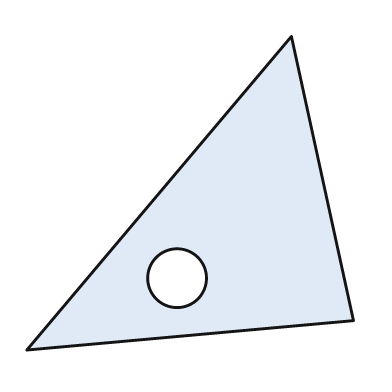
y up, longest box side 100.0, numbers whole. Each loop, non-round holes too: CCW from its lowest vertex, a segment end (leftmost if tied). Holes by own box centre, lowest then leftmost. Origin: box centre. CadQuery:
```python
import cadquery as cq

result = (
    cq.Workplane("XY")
    .moveTo(-50.0, -48.0)
    .lineTo(50.0, -39.0)
    .lineTo(31.0, 48.0)
    .close()
    .moveTo(-4.0, -26.0)
    .circle(9.0)
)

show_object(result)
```